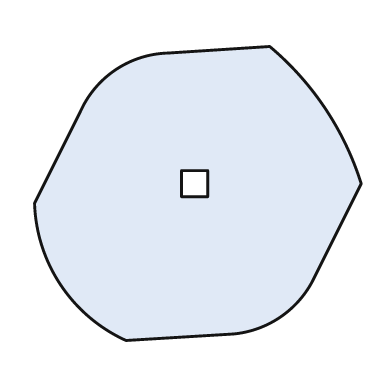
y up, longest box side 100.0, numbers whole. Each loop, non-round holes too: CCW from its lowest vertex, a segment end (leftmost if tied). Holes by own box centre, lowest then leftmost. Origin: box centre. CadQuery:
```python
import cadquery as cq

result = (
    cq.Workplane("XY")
    .moveTo(-22.0, -45.0)
    .lineTo(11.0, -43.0)
    .threePointArc((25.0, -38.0), (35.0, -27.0))
    .lineTo(50.0, 3.0)
    .threePointArc((39.0, 26.0), (22.0, 45.0))
    .lineTo(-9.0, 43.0)
    .threePointArc((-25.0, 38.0), (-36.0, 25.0))
    .lineTo(-50.0, -3.0)
    .threePointArc((-42.0, -28.0), (-22.0, -45.0))
    .close()
    .moveTo(-5.0, -1.0)
    .lineTo(3.0, -1.0)
    .lineTo(3.0, 7.0)
    .lineTo(-5.0, 7.0)
    .close()
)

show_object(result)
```